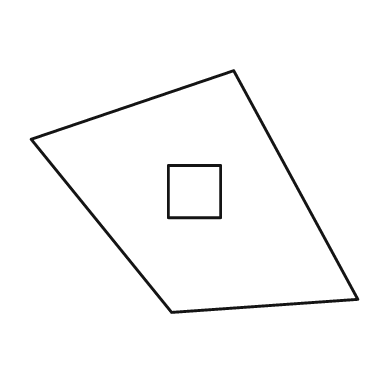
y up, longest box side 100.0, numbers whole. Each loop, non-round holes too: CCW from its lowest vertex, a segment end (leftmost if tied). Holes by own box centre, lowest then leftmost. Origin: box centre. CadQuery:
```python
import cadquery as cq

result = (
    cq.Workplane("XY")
    .moveTo(-7.0, -37.0)
    .lineTo(50.0, -33.0)
    .lineTo(12.0, 37.0)
    .lineTo(-50.0, 16.0)
    .close()
    .moveTo(-8.0, -8.0)
    .lineTo(8.0, -8.0)
    .lineTo(8.0, 8.0)
    .lineTo(-8.0, 8.0)
    .close()
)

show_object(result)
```